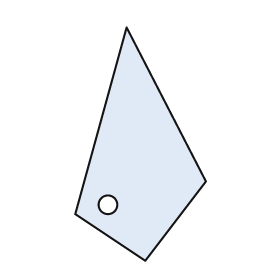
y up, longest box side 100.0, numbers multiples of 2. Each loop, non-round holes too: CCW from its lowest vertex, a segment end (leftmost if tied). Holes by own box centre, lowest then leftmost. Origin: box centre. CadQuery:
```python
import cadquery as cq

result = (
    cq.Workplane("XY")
    .moveTo(2.0, -50.0)
    .lineTo(28.0, -16.0)
    .lineTo(-6.0, 50.0)
    .lineTo(-28.0, -30.0)
    .close()
    .moveTo(-14.0, -26.0)
    .circle(4.0)
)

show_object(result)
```